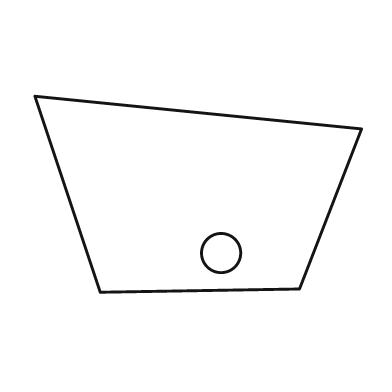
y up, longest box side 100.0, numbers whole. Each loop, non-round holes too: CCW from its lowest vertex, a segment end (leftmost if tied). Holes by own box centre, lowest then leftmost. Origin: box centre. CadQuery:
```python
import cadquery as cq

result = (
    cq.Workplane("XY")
    .moveTo(-30.0, -30.0)
    .lineTo(31.0, -29.0)
    .lineTo(50.0, 20.0)
    .lineTo(-50.0, 30.0)
    .close()
    .moveTo(7.0, -18.0)
    .circle(6.0)
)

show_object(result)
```